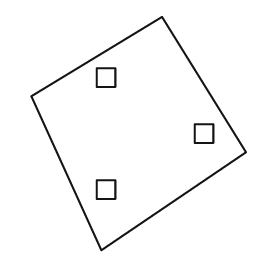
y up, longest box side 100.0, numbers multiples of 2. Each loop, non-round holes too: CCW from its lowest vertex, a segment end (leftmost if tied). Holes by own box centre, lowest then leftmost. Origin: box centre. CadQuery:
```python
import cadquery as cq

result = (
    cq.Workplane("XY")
    .moveTo(-16.0, -50.0)
    .lineTo(46.0, -8.0)
    .lineTo(10.0, 50.0)
    .lineTo(-46.0, 16.0)
    .close()
    .moveTo(-18.0, -28.0)
    .lineTo(-10.0, -28.0)
    .lineTo(-10.0, -20.0)
    .lineTo(-18.0, -20.0)
    .close()
    .moveTo(24.0, -4.0)
    .lineTo(32.0, -4.0)
    .lineTo(32.0, 4.0)
    .lineTo(24.0, 4.0)
    .close()
    .moveTo(-18.0, 20.0)
    .lineTo(-10.0, 20.0)
    .lineTo(-10.0, 28.0)
    .lineTo(-18.0, 28.0)
    .close()
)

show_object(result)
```